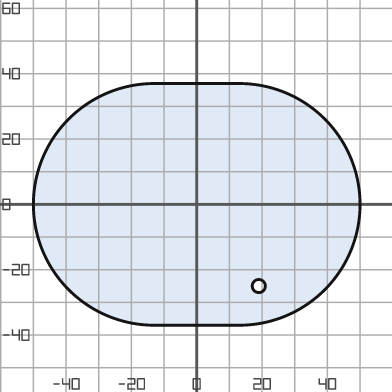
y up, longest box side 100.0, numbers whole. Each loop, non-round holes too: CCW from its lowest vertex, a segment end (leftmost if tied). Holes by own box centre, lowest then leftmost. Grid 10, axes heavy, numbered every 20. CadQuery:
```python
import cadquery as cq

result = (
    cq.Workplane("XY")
    .moveTo(-13.0, -37.0)
    .lineTo(13.0, -37.0)
    .threePointArc((50.0, 0.0), (13.0, 37.0))
    .lineTo(-13.0, 37.0)
    .threePointArc((-50.0, 0.0), (-13.0, -37.0))
    .close()
    .moveTo(19.0, -25.0)
    .circle(2.0)
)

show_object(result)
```